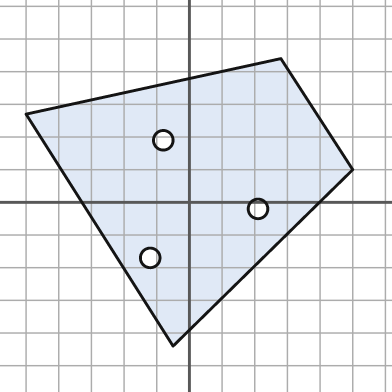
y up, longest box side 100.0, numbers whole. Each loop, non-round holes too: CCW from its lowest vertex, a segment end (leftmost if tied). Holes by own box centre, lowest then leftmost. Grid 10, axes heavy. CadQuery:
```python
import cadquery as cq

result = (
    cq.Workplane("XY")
    .moveTo(-5.0, -44.0)
    .lineTo(50.0, 10.0)
    .lineTo(28.0, 44.0)
    .lineTo(-50.0, 27.0)
    .close()
    .moveTo(-12.0, -17.0)
    .circle(3.0)
    .moveTo(21.0, -2.0)
    .circle(3.0)
    .moveTo(-8.0, 19.0)
    .circle(3.0)
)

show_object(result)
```